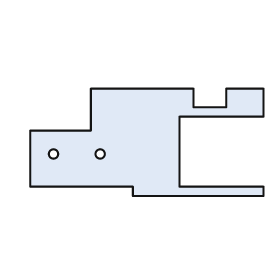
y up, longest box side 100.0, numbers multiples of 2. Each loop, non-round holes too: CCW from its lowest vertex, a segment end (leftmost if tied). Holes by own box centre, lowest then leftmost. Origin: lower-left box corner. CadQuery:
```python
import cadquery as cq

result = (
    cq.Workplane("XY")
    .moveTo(44.0, 0.0)
    .lineTo(100.0, 0.0)
    .lineTo(100.0, 4.0)
    .lineTo(64.0, 4.0)
    .lineTo(64.0, 34.0)
    .lineTo(100.0, 34.0)
    .lineTo(100.0, 46.0)
    .lineTo(84.0, 46.0)
    .lineTo(84.0, 38.0)
    .lineTo(70.0, 38.0)
    .lineTo(70.0, 46.0)
    .lineTo(26.0, 46.0)
    .lineTo(26.0, 28.0)
    .lineTo(0.0, 28.0)
    .lineTo(0.0, 4.0)
    .lineTo(44.0, 4.0)
    .close()
    .moveTo(10.0, 18.0)
    .circle(2.0)
    .moveTo(30.0, 18.0)
    .circle(2.0)
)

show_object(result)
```